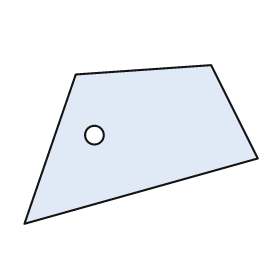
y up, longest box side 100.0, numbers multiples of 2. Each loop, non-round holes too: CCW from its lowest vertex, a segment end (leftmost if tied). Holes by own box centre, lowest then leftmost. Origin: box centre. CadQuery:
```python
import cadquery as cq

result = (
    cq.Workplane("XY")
    .moveTo(-50.0, -34.0)
    .lineTo(50.0, -6.0)
    .lineTo(30.0, 34.0)
    .lineTo(-28.0, 30.0)
    .close()
    .moveTo(-20.0, 4.0)
    .circle(4.0)
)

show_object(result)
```